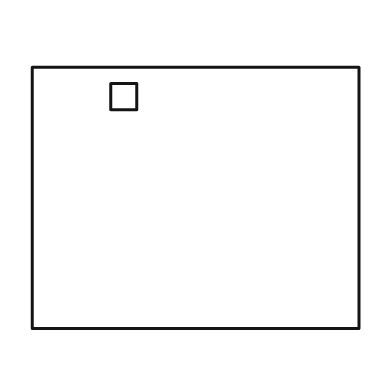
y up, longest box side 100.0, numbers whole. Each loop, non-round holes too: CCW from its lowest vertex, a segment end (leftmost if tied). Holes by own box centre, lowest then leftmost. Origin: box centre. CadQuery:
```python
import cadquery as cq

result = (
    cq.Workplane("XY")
    .moveTo(-50.0, -40.0)
    .lineTo(50.0, -40.0)
    .lineTo(50.0, 40.0)
    .lineTo(-50.0, 40.0)
    .close()
    .moveTo(-26.0, 27.0)
    .lineTo(-18.0, 27.0)
    .lineTo(-18.0, 35.0)
    .lineTo(-26.0, 35.0)
    .close()
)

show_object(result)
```